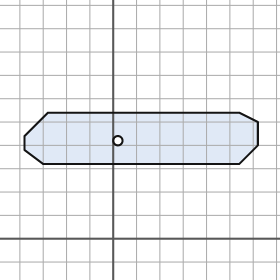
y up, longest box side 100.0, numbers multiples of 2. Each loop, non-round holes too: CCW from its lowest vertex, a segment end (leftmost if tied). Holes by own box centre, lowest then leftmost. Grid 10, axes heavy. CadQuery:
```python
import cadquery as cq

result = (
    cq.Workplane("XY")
    .moveTo(-30.0, 32.0)
    .lineTo(54.0, 32.0)
    .lineTo(62.0, 40.0)
    .lineTo(62.0, 50.0)
    .lineTo(54.0, 54.0)
    .lineTo(-28.0, 54.0)
    .lineTo(-38.0, 44.0)
    .lineTo(-38.0, 38.0)
    .close()
    .moveTo(2.0, 42.0)
    .circle(2.0)
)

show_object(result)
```